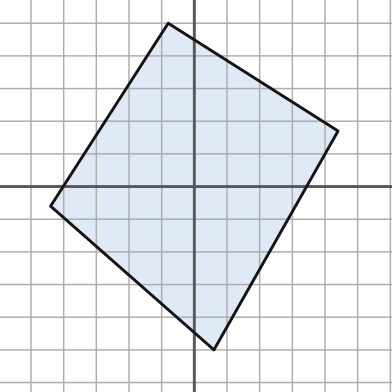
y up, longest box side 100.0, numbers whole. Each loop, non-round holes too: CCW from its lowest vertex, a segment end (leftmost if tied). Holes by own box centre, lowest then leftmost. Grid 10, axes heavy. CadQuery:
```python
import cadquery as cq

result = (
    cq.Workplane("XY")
    .moveTo(6.0, -50.0)
    .lineTo(44.0, 17.0)
    .lineTo(-8.0, 50.0)
    .lineTo(-44.0, -6.0)
    .close()
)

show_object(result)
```